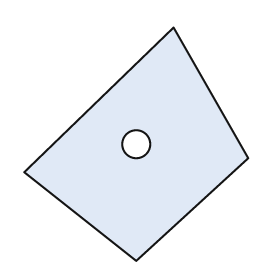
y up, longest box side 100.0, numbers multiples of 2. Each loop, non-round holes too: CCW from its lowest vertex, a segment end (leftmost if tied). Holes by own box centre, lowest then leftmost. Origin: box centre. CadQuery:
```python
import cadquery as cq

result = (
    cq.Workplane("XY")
    .moveTo(0.0, -50.0)
    .lineTo(48.0, -6.0)
    .lineTo(16.0, 50.0)
    .lineTo(-48.0, -12.0)
    .close()
    .moveTo(0.0, 0.0)
    .circle(6.0)
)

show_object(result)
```